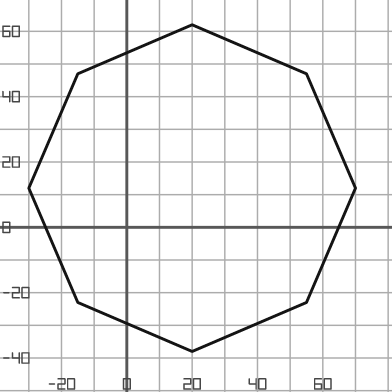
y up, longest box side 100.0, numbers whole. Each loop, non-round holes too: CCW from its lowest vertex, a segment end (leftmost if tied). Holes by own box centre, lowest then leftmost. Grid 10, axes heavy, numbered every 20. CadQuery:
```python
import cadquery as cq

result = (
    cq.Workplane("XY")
    .moveTo(20.0, -38.0)
    .lineTo(55.0, -23.0)
    .lineTo(70.0, 12.0)
    .lineTo(55.0, 47.0)
    .lineTo(20.0, 62.0)
    .lineTo(-15.0, 47.0)
    .lineTo(-30.0, 12.0)
    .lineTo(-15.0, -23.0)
    .close()
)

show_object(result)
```